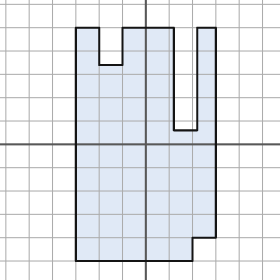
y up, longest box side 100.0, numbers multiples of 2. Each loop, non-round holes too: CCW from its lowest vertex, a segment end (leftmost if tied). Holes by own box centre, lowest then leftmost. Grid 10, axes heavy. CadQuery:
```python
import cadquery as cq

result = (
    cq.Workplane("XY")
    .moveTo(-30.0, -50.0)
    .lineTo(20.0, -50.0)
    .lineTo(20.0, -40.0)
    .lineTo(30.0, -40.0)
    .lineTo(30.0, 50.0)
    .lineTo(22.0, 50.0)
    .lineTo(22.0, 6.0)
    .lineTo(12.0, 6.0)
    .lineTo(12.0, 50.0)
    .lineTo(-10.0, 50.0)
    .lineTo(-10.0, 34.0)
    .lineTo(-20.0, 34.0)
    .lineTo(-20.0, 50.0)
    .lineTo(-30.0, 50.0)
    .close()
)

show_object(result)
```